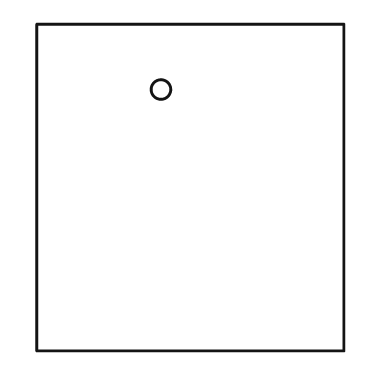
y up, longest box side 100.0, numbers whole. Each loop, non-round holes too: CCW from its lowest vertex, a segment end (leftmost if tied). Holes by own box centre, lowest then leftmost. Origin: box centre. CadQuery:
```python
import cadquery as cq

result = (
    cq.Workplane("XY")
    .moveTo(-47.0, -50.0)
    .lineTo(47.0, -50.0)
    .lineTo(47.0, 50.0)
    .lineTo(-47.0, 50.0)
    .close()
    .moveTo(-9.0, 30.0)
    .circle(3.0)
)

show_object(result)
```